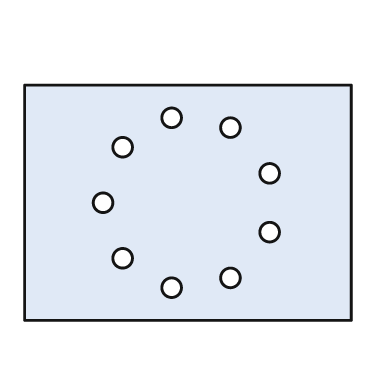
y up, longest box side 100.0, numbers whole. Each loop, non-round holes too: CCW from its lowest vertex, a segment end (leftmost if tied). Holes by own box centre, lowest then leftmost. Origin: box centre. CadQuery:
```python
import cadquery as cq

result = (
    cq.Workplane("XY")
    .moveTo(-50.0, -36.0)
    .lineTo(50.0, -36.0)
    .lineTo(50.0, 36.0)
    .lineTo(-50.0, 36.0)
    .close()
    .moveTo(-5.0, -26.0)
    .circle(3.0)
    .moveTo(13.0, -23.0)
    .circle(3.0)
    .moveTo(-20.0, -17.0)
    .circle(3.0)
    .moveTo(25.0, -9.0)
    .circle(3.0)
    .moveTo(-26.0, 0.0)
    .circle(3.0)
    .moveTo(25.0, 9.0)
    .circle(3.0)
    .moveTo(-20.0, 17.0)
    .circle(3.0)
    .moveTo(13.0, 23.0)
    .circle(3.0)
    .moveTo(-5.0, 26.0)
    .circle(3.0)
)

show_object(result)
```